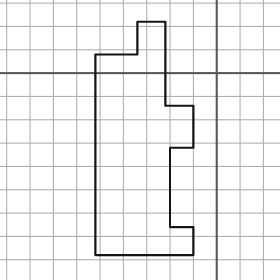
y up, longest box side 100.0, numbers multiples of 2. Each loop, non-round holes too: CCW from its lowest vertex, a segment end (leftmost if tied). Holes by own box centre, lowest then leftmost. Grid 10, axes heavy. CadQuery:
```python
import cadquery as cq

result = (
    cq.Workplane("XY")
    .moveTo(-52.0, -78.0)
    .lineTo(-10.0, -78.0)
    .lineTo(-10.0, -66.0)
    .lineTo(-20.0, -66.0)
    .lineTo(-20.0, -32.0)
    .lineTo(-10.0, -32.0)
    .lineTo(-10.0, -14.0)
    .lineTo(-22.0, -14.0)
    .lineTo(-22.0, 22.0)
    .lineTo(-34.0, 22.0)
    .lineTo(-34.0, 8.0)
    .lineTo(-52.0, 8.0)
    .close()
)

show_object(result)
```